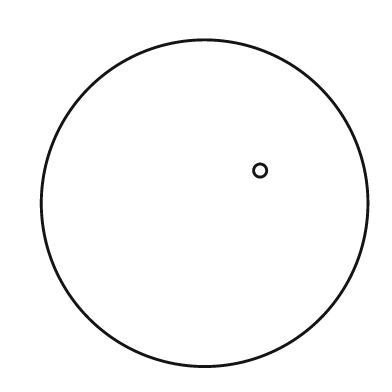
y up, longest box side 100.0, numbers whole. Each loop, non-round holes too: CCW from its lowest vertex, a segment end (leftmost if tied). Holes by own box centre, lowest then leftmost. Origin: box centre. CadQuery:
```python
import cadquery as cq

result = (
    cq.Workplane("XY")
    .moveTo(0.0, 0.0)
    .circle(50.0)
    .moveTo(17.0, 10.0)
    .circle(2.0)
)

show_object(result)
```